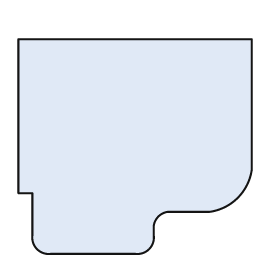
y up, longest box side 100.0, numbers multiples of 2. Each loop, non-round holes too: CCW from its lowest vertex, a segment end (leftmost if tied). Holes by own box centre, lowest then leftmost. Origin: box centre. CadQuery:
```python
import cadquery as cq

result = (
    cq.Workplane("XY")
    .moveTo(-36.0, -46.0)
    .lineTo(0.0, -46.0)
    .threePointArc((6.0, -44.0), (8.0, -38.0))
    .lineTo(8.0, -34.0)
    .threePointArc((10.0, -30.0), (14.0, -28.0))
    .lineTo(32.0, -28.0)
    .threePointArc((44.0, -22.0), (50.0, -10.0))
    .lineTo(50.0, 46.0)
    .lineTo(-50.0, 46.0)
    .lineTo(-50.0, -20.0)
    .lineTo(-44.0, -20.0)
    .lineTo(-44.0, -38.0)
    .threePointArc((-42.0, -44.0), (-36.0, -46.0))
    .close()
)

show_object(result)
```